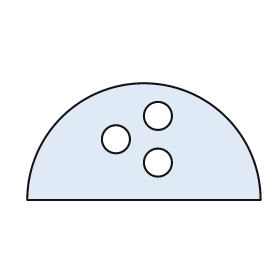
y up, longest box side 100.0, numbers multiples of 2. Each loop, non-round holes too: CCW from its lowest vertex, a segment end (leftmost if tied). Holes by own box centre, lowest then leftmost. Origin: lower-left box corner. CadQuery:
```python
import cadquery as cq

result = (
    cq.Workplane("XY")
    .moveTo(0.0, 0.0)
    .lineTo(100.0, 0.0)
    .threePointArc((50.0, 50.0), (0.0, 0.0))
    .close()
    .moveTo(56.0, 16.0)
    .circle(6.0)
    .moveTo(38.0, 26.0)
    .circle(6.0)
    .moveTo(56.0, 36.0)
    .circle(6.0)
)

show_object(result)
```